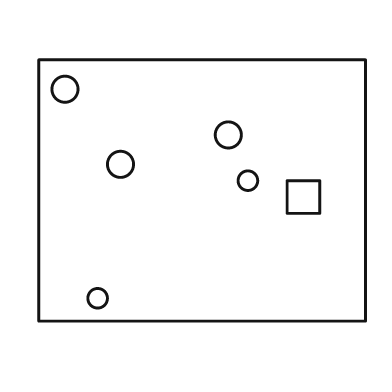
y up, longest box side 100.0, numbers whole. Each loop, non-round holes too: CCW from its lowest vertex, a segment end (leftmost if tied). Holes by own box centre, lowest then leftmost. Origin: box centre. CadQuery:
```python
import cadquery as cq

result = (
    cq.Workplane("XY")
    .moveTo(-50.0, -40.0)
    .lineTo(50.0, -40.0)
    .lineTo(50.0, 40.0)
    .lineTo(-50.0, 40.0)
    .close()
    .moveTo(-32.0, -33.0)
    .circle(3.0)
    .moveTo(26.0, -7.0)
    .lineTo(36.0, -7.0)
    .lineTo(36.0, 3.0)
    .lineTo(26.0, 3.0)
    .close()
    .moveTo(14.0, 3.0)
    .circle(3.0)
    .moveTo(-25.0, 8.0)
    .circle(4.0)
    .moveTo(8.0, 17.0)
    .circle(4.0)
    .moveTo(-42.0, 31.0)
    .circle(4.0)
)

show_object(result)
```